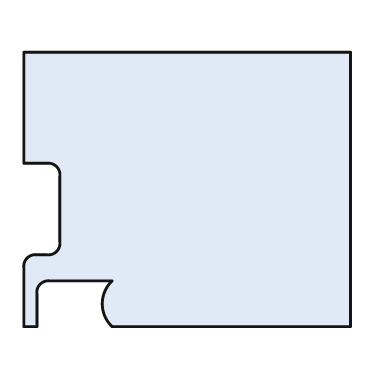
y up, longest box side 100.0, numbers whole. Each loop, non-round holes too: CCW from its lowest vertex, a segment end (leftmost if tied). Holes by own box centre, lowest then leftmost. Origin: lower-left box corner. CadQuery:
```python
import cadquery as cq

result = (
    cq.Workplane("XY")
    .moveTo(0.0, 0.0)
    .lineTo(4.0, 0.0)
    .lineTo(4.0, 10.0)
    .threePointArc((5.0, 13.0), (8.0, 14.0))
    .lineTo(27.0, 14.0)
    .threePointArc((24.0, 7.0), (27.0, 0.0))
    .lineTo(100.0, 0.0)
    .lineTo(100.0, 84.0)
    .lineTo(0.0, 84.0)
    .lineTo(0.0, 50.0)
    .lineTo(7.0, 50.0)
    .threePointArc((10.0, 49.0), (11.0, 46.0))
    .lineTo(11.0, 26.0)
    .threePointArc((10.0, 23.0), (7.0, 22.0))
    .lineTo(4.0, 22.0)
    .threePointArc((1.0, 21.0), (0.0, 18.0))
    .close()
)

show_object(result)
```